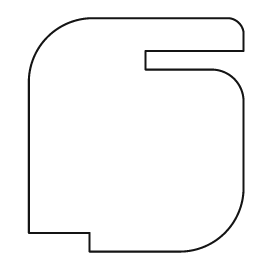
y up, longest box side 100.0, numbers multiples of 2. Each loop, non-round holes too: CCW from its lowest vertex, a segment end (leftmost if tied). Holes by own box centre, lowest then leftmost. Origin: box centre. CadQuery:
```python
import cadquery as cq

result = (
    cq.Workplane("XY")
    .moveTo(-20.0, -50.0)
    .lineTo(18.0, -50.0)
    .threePointArc((38.0, -42.0), (46.0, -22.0))
    .lineTo(46.0, 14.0)
    .threePointArc((42.0, 24.0), (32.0, 28.0))
    .lineTo(4.0, 28.0)
    .lineTo(4.0, 36.0)
    .lineTo(46.0, 36.0)
    .lineTo(46.0, 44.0)
    .threePointArc((44.0, 48.0), (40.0, 50.0))
    .lineTo(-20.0, 50.0)
    .threePointArc((-38.0, 42.0), (-46.0, 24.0))
    .lineTo(-46.0, -42.0)
    .lineTo(-20.0, -42.0)
    .close()
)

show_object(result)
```